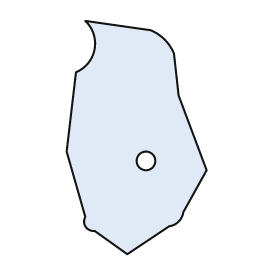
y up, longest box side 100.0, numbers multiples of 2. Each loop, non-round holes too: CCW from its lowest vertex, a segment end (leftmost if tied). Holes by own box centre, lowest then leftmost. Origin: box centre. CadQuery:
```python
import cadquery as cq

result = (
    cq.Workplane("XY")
    .moveTo(-4.0, -50.0)
    .lineTo(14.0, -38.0)
    .threePointArc((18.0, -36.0), (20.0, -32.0))
    .lineTo(30.0, -14.0)
    .lineTo(18.0, 18.0)
    .lineTo(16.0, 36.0)
    .threePointArc((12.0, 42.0), (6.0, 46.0))
    .lineTo(-22.0, 50.0)
    .threePointArc((-18.0, 38.0), (-26.0, 28.0))
    .lineTo(-30.0, -6.0)
    .lineTo(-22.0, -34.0)
    .threePointArc((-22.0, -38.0), (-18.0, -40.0))
    .close()
    .moveTo(4.0, -10.0)
    .circle(4.0)
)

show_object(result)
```